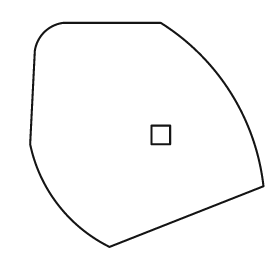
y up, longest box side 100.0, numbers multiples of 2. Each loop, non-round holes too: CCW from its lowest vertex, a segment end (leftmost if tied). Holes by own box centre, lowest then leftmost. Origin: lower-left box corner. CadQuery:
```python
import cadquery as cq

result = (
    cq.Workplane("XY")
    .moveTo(34.0, 0.0)
    .lineTo(100.0, 26.0)
    .threePointArc((86.0, 66.0), (56.0, 96.0))
    .lineTo(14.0, 96.0)
    .threePointArc((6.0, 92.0), (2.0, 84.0))
    .lineTo(0.0, 44.0)
    .threePointArc((12.0, 18.0), (34.0, 0.0))
    .close()
    .moveTo(52.0, 44.0)
    .lineTo(60.0, 44.0)
    .lineTo(60.0, 52.0)
    .lineTo(52.0, 52.0)
    .close()
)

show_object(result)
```